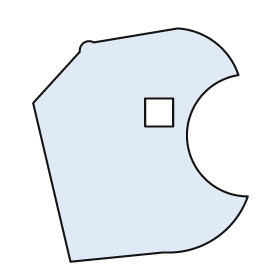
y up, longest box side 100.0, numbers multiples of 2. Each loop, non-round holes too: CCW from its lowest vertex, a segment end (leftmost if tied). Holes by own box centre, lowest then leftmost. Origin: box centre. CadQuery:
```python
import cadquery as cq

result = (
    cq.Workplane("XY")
    .moveTo(-30.0, -50.0)
    .lineTo(10.0, -46.0)
    .threePointArc((32.0, -40.0), (46.0, -22.0))
    .threePointArc((20.0, 2.0), (42.0, 30.0))
    .threePointArc((32.0, 44.0), (16.0, 50.0))
    .lineTo(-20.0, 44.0)
    .threePointArc((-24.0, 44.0), (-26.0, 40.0))
    .lineTo(-46.0, 18.0)
    .close()
    .moveTo(2.0, 8.0)
    .lineTo(14.0, 8.0)
    .lineTo(14.0, 20.0)
    .lineTo(2.0, 20.0)
    .close()
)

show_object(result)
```